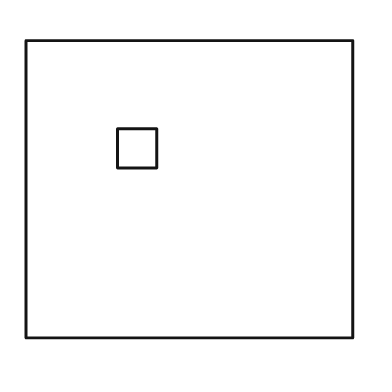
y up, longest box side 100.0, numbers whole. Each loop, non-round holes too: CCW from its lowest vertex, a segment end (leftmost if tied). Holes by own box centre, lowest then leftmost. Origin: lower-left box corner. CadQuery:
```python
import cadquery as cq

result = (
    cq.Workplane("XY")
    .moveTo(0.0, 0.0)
    .lineTo(100.0, 0.0)
    .lineTo(100.0, 91.0)
    .lineTo(0.0, 91.0)
    .close()
    .moveTo(28.0, 52.0)
    .lineTo(40.0, 52.0)
    .lineTo(40.0, 64.0)
    .lineTo(28.0, 64.0)
    .close()
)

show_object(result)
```